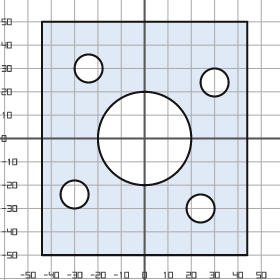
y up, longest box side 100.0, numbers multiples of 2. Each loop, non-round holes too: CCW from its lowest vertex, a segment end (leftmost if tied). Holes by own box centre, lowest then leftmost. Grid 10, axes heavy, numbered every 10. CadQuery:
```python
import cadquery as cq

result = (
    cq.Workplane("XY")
    .moveTo(-44.0, -50.0)
    .lineTo(44.0, -50.0)
    .lineTo(44.0, 50.0)
    .lineTo(-44.0, 50.0)
    .close()
    .moveTo(24.0, -30.0)
    .circle(6.0)
    .moveTo(-30.0, -24.0)
    .circle(6.0)
    .moveTo(0.0, 0.0)
    .circle(20.0)
    .moveTo(30.0, 24.0)
    .circle(6.0)
    .moveTo(-24.0, 30.0)
    .circle(6.0)
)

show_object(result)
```